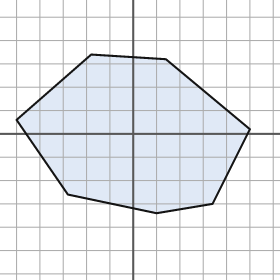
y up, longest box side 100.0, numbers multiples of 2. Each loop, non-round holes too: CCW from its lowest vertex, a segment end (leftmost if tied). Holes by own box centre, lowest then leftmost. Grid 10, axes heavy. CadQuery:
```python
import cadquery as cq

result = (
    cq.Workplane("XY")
    .moveTo(10.0, -34.0)
    .lineTo(34.0, -30.0)
    .lineTo(50.0, 2.0)
    .lineTo(14.0, 32.0)
    .lineTo(-18.0, 34.0)
    .lineTo(-50.0, 6.0)
    .lineTo(-28.0, -26.0)
    .close()
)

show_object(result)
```